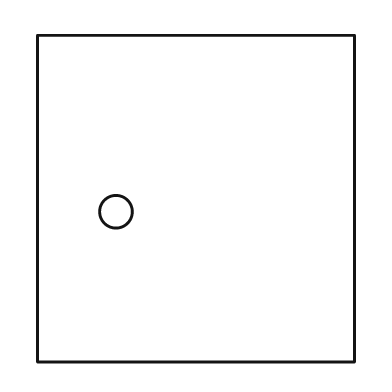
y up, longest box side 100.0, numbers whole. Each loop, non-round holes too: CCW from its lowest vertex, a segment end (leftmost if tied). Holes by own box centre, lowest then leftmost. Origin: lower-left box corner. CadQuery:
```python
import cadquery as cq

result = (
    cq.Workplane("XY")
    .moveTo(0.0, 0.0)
    .lineTo(97.0, 0.0)
    .lineTo(97.0, 100.0)
    .lineTo(0.0, 100.0)
    .close()
    .moveTo(24.0, 46.0)
    .circle(5.0)
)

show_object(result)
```